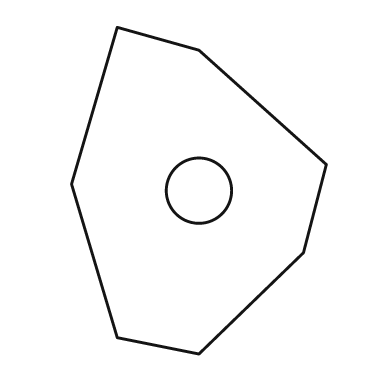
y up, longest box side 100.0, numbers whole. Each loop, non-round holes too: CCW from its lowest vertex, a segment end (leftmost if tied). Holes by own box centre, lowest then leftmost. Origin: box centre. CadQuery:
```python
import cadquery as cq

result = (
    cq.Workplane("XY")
    .moveTo(0.0, -50.0)
    .lineTo(32.0, -19.0)
    .lineTo(39.0, 8.0)
    .lineTo(0.0, 43.0)
    .lineTo(-25.0, 50.0)
    .lineTo(-39.0, 2.0)
    .lineTo(-25.0, -45.0)
    .close()
    .moveTo(0.0, 0.0)
    .circle(10.0)
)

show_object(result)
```